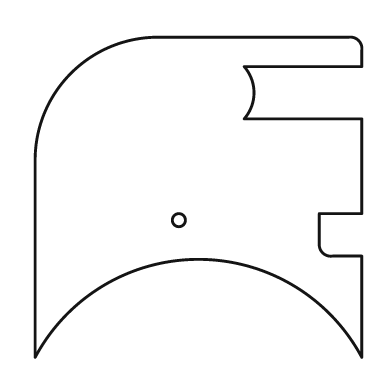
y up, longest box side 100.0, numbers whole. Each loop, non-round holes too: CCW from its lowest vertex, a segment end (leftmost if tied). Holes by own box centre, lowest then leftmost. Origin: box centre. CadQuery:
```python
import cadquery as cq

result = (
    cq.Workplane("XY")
    .moveTo(-50.0, -49.0)
    .threePointArc((0.0, -19.0), (50.0, -49.0))
    .lineTo(50.0, -18.0)
    .lineTo(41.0, -18.0)
    .threePointArc((38.0, -17.0), (37.0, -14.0))
    .lineTo(37.0, -5.0)
    .lineTo(50.0, -5.0)
    .lineTo(50.0, 24.0)
    .lineTo(14.0, 24.0)
    .threePointArc((17.0, 32.0), (14.0, 40.0))
    .lineTo(50.0, 40.0)
    .lineTo(50.0, 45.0)
    .threePointArc((49.0, 48.0), (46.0, 49.0))
    .lineTo(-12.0, 49.0)
    .threePointArc((-39.0, 38.0), (-50.0, 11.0))
    .close()
    .moveTo(-6.0, -7.0)
    .circle(2.0)
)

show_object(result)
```